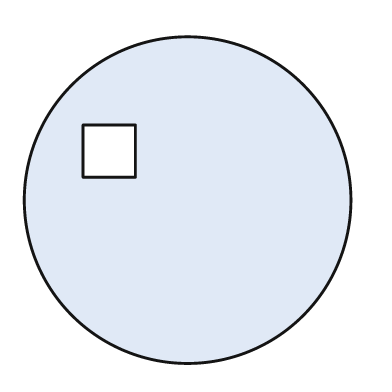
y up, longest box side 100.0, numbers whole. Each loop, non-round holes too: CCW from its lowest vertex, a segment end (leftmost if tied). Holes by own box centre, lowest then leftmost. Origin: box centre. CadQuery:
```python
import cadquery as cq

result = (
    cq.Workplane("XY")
    .moveTo(0.0, 0.0)
    .circle(50.0)
    .moveTo(-32.0, 7.0)
    .lineTo(-16.0, 7.0)
    .lineTo(-16.0, 23.0)
    .lineTo(-32.0, 23.0)
    .close()
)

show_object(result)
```